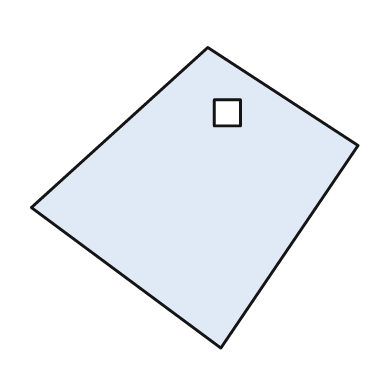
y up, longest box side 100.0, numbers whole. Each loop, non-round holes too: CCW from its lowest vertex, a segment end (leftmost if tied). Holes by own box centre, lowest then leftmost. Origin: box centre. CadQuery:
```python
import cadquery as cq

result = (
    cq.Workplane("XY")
    .moveTo(8.0, -46.0)
    .lineTo(50.0, 16.0)
    .lineTo(4.0, 46.0)
    .lineTo(-50.0, -3.0)
    .close()
    .moveTo(6.0, 22.0)
    .lineTo(14.0, 22.0)
    .lineTo(14.0, 30.0)
    .lineTo(6.0, 30.0)
    .close()
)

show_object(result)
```